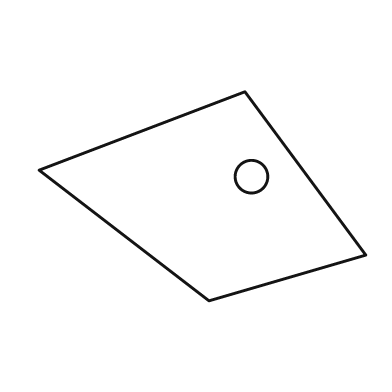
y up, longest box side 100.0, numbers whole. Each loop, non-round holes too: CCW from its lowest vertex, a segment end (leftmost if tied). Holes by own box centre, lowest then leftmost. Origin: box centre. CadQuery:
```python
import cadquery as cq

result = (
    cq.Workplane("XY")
    .moveTo(2.0, -32.0)
    .lineTo(50.0, -18.0)
    .lineTo(13.0, 32.0)
    .lineTo(-50.0, 8.0)
    .close()
    .moveTo(15.0, 6.0)
    .circle(5.0)
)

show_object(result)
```